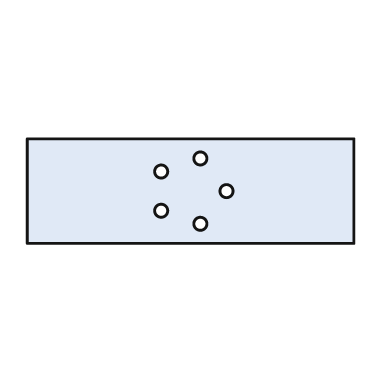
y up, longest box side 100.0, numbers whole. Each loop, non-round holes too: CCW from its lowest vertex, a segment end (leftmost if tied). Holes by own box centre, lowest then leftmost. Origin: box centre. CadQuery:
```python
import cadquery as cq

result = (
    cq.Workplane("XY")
    .moveTo(-50.0, -16.0)
    .lineTo(50.0, -16.0)
    .lineTo(50.0, 16.0)
    .lineTo(-50.0, 16.0)
    .close()
    .moveTo(3.0, -10.0)
    .circle(2.0)
    .moveTo(-9.0, -6.0)
    .circle(2.0)
    .moveTo(11.0, 0.0)
    .circle(2.0)
    .moveTo(-9.0, 6.0)
    .circle(2.0)
    .moveTo(3.0, 10.0)
    .circle(2.0)
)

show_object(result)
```